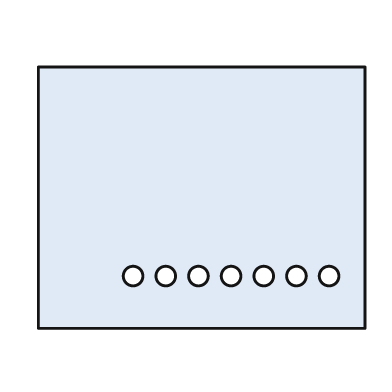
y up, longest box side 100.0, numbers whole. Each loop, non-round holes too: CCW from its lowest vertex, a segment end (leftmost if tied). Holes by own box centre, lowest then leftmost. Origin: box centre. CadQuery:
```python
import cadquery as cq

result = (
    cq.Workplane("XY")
    .moveTo(-50.0, -40.0)
    .lineTo(50.0, -40.0)
    .lineTo(50.0, 40.0)
    .lineTo(-50.0, 40.0)
    .close()
    .moveTo(-21.0, -24.0)
    .circle(3.0)
    .moveTo(-11.0, -24.0)
    .circle(3.0)
    .moveTo(-1.0, -24.0)
    .circle(3.0)
    .moveTo(9.0, -24.0)
    .circle(3.0)
    .moveTo(19.0, -24.0)
    .circle(3.0)
    .moveTo(29.0, -24.0)
    .circle(3.0)
    .moveTo(39.0, -24.0)
    .circle(3.0)
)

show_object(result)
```